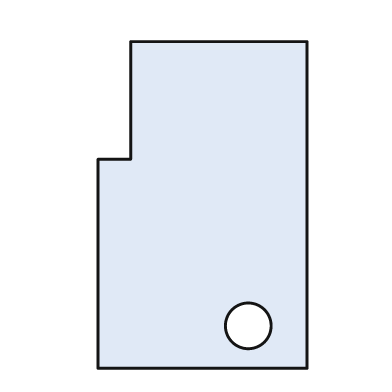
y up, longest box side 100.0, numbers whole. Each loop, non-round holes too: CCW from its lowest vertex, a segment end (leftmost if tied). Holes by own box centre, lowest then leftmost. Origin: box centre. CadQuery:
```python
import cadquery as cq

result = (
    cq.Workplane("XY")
    .moveTo(-32.0, -50.0)
    .lineTo(32.0, -50.0)
    .lineTo(32.0, 50.0)
    .lineTo(-22.0, 50.0)
    .lineTo(-22.0, 14.0)
    .lineTo(-32.0, 14.0)
    .close()
    .moveTo(14.0, -37.0)
    .circle(7.0)
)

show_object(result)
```